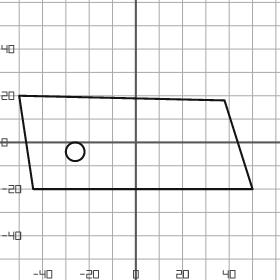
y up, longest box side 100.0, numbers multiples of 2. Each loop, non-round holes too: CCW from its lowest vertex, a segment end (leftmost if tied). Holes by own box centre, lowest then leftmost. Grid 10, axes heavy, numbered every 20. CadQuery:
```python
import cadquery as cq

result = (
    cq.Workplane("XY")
    .moveTo(-44.0, -20.0)
    .lineTo(50.0, -20.0)
    .lineTo(38.0, 18.0)
    .lineTo(-50.0, 20.0)
    .close()
    .moveTo(-26.0, -4.0)
    .circle(4.0)
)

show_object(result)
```